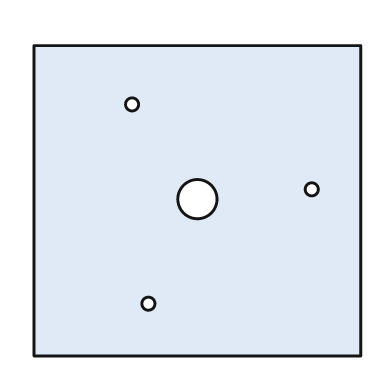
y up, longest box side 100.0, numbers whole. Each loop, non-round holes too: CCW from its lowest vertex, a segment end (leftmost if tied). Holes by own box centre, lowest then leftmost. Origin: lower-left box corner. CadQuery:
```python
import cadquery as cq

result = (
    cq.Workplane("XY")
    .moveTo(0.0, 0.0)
    .lineTo(100.0, 0.0)
    .lineTo(100.0, 95.0)
    .lineTo(0.0, 95.0)
    .close()
    .moveTo(35.0, 16.0)
    .circle(2.0)
    .moveTo(50.0, 48.0)
    .circle(6.0)
    .moveTo(85.0, 51.0)
    .circle(2.0)
    .moveTo(30.0, 77.0)
    .circle(2.0)
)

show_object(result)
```